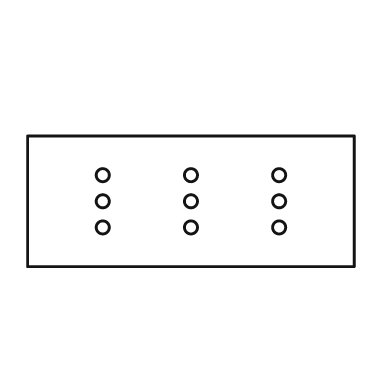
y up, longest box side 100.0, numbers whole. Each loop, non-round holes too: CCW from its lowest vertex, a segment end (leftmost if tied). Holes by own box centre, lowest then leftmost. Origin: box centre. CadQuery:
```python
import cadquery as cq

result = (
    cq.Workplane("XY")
    .moveTo(-50.0, -20.0)
    .lineTo(50.0, -20.0)
    .lineTo(50.0, 20.0)
    .lineTo(-50.0, 20.0)
    .close()
    .moveTo(-27.0, -8.0)
    .circle(2.0)
    .moveTo(0.0, -8.0)
    .circle(2.0)
    .moveTo(27.0, -8.0)
    .circle(2.0)
    .moveTo(-27.0, 0.0)
    .circle(2.0)
    .moveTo(0.0, 0.0)
    .circle(2.0)
    .moveTo(27.0, 0.0)
    .circle(2.0)
    .moveTo(-27.0, 8.0)
    .circle(2.0)
    .moveTo(0.0, 8.0)
    .circle(2.0)
    .moveTo(27.0, 8.0)
    .circle(2.0)
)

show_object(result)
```